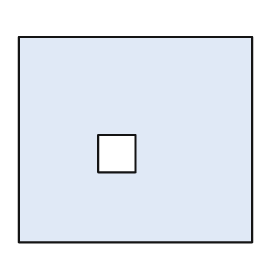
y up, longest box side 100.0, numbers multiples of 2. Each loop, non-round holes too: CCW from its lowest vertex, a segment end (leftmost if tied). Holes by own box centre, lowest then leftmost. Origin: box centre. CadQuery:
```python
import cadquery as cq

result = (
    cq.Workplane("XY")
    .moveTo(-50.0, -44.0)
    .lineTo(50.0, -44.0)
    .lineTo(50.0, 44.0)
    .lineTo(-50.0, 44.0)
    .close()
    .moveTo(-16.0, -14.0)
    .lineTo(0.0, -14.0)
    .lineTo(0.0, 2.0)
    .lineTo(-16.0, 2.0)
    .close()
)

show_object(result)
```